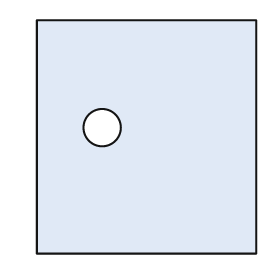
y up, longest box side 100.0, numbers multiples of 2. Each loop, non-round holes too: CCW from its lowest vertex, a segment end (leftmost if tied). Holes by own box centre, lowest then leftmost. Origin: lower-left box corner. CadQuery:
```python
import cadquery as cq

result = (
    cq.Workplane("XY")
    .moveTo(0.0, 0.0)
    .lineTo(94.0, 0.0)
    .lineTo(94.0, 100.0)
    .lineTo(0.0, 100.0)
    .close()
    .moveTo(28.0, 54.0)
    .circle(8.0)
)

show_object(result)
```